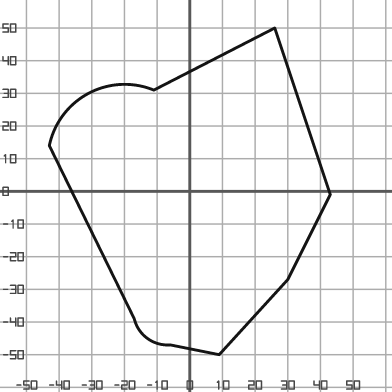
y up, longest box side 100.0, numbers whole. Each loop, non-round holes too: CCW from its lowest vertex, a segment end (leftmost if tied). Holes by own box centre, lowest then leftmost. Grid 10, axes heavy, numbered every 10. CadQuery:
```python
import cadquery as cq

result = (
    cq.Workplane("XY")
    .moveTo(9.0, -50.0)
    .lineTo(30.0, -27.0)
    .lineTo(43.0, -1.0)
    .lineTo(26.0, 50.0)
    .lineTo(-11.0, 31.0)
    .threePointArc((-31.0, 30.0), (-43.0, 14.0))
    .lineTo(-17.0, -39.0)
    .threePointArc((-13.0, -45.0), (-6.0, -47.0))
    .close()
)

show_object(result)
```